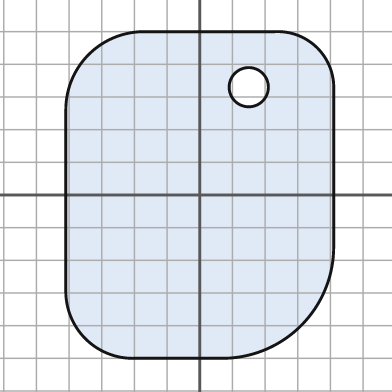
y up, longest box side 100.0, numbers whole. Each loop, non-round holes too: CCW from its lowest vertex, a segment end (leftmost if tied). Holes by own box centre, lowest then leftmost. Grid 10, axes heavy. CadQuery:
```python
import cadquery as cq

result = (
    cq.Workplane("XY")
    .moveTo(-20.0, -50.0)
    .lineTo(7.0, -50.0)
    .threePointArc((31.0, -40.0), (41.0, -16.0))
    .lineTo(41.0, 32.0)
    .threePointArc((36.0, 45.0), (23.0, 50.0))
    .lineTo(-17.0, 50.0)
    .threePointArc((-34.0, 43.0), (-41.0, 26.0))
    .lineTo(-41.0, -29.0)
    .threePointArc((-35.0, -44.0), (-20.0, -50.0))
    .close()
    .moveTo(15.0, 33.0)
    .circle(6.0)
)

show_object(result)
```